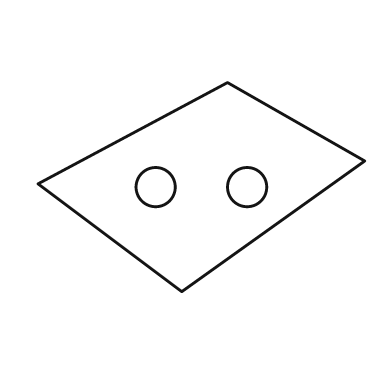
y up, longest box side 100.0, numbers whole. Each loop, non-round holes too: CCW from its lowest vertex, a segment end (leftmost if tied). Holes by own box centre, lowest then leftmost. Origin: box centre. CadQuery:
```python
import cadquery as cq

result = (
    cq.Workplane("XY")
    .moveTo(-6.0, -32.0)
    .lineTo(50.0, 8.0)
    .lineTo(8.0, 32.0)
    .lineTo(-50.0, 1.0)
    .close()
    .moveTo(-14.0, 0.0)
    .circle(6.0)
    .moveTo(14.0, 0.0)
    .circle(6.0)
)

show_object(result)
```